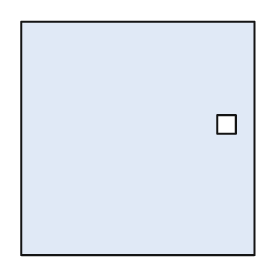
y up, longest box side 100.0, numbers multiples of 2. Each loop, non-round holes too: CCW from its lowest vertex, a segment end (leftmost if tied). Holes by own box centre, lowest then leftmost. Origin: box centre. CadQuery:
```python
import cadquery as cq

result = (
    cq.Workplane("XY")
    .moveTo(-50.0, -50.0)
    .lineTo(50.0, -50.0)
    .lineTo(50.0, 50.0)
    .lineTo(-50.0, 50.0)
    .close()
    .moveTo(34.0, 2.0)
    .lineTo(42.0, 2.0)
    .lineTo(42.0, 10.0)
    .lineTo(34.0, 10.0)
    .close()
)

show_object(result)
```